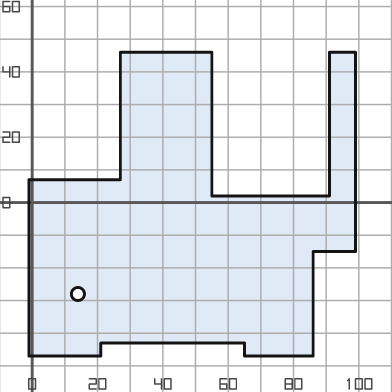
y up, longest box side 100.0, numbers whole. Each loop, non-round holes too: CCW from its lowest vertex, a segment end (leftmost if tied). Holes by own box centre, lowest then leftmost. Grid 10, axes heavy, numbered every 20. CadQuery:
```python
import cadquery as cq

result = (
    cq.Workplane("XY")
    .moveTo(-1.0, -47.0)
    .lineTo(21.0, -47.0)
    .lineTo(21.0, -43.0)
    .lineTo(65.0, -43.0)
    .lineTo(65.0, -47.0)
    .lineTo(86.0, -47.0)
    .lineTo(86.0, -15.0)
    .lineTo(99.0, -15.0)
    .lineTo(99.0, 46.0)
    .lineTo(91.0, 46.0)
    .lineTo(91.0, 2.0)
    .lineTo(55.0, 2.0)
    .lineTo(55.0, 46.0)
    .lineTo(27.0, 46.0)
    .lineTo(27.0, 7.0)
    .lineTo(-1.0, 7.0)
    .close()
    .moveTo(14.0, -28.0)
    .circle(2.0)
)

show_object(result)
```